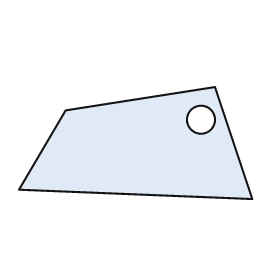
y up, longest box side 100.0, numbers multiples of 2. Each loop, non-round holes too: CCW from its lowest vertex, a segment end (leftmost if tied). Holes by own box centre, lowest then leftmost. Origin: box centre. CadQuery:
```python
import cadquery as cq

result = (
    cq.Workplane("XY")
    .moveTo(50.0, -24.0)
    .lineTo(34.0, 24.0)
    .lineTo(-30.0, 14.0)
    .lineTo(-50.0, -20.0)
    .close()
    .moveTo(28.0, 10.0)
    .circle(6.0)
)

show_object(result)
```